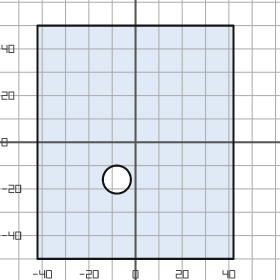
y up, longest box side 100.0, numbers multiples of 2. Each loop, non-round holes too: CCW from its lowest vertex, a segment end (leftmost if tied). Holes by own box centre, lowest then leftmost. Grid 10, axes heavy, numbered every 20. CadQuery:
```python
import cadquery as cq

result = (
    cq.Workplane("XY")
    .moveTo(-42.0, -50.0)
    .lineTo(42.0, -50.0)
    .lineTo(42.0, 50.0)
    .lineTo(-42.0, 50.0)
    .close()
    .moveTo(-8.0, -16.0)
    .circle(6.0)
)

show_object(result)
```